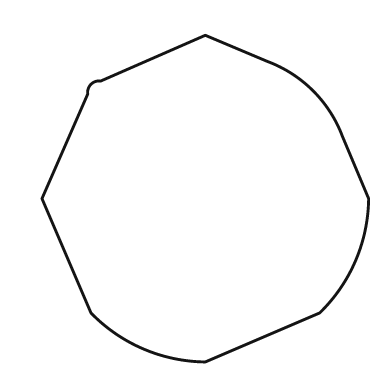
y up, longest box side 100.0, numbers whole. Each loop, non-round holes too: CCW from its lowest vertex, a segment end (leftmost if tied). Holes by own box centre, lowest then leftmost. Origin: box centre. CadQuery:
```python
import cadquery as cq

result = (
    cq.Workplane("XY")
    .moveTo(0.0, -50.0)
    .lineTo(35.0, -35.0)
    .threePointArc((46.0, -19.0), (50.0, 0.0))
    .lineTo(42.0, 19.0)
    .threePointArc((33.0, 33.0), (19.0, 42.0))
    .lineTo(0.0, 50.0)
    .lineTo(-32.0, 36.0)
    .threePointArc((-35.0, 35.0), (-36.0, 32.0))
    .lineTo(-50.0, 0.0)
    .lineTo(-35.0, -35.0)
    .threePointArc((-19.0, -46.0), (0.0, -50.0))
    .close()
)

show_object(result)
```